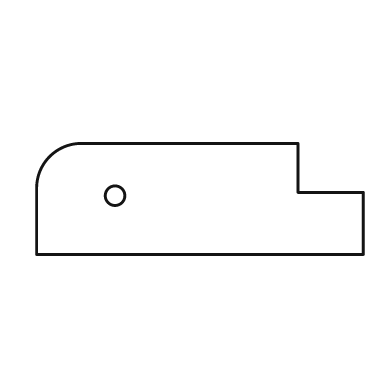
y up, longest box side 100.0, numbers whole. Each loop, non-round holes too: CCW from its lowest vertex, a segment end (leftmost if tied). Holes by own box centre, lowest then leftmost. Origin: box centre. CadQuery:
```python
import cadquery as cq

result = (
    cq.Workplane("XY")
    .moveTo(-50.0, -17.0)
    .lineTo(50.0, -17.0)
    .lineTo(50.0, 2.0)
    .lineTo(30.0, 2.0)
    .lineTo(30.0, 17.0)
    .lineTo(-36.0, 17.0)
    .threePointArc((-46.0, 13.0), (-50.0, 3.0))
    .close()
    .moveTo(-26.0, 1.0)
    .circle(3.0)
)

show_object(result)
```